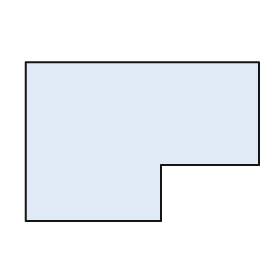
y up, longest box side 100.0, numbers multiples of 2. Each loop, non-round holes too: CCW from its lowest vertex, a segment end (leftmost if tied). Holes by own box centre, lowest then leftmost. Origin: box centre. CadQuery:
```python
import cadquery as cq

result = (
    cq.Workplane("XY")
    .moveTo(-50.0, -34.0)
    .lineTo(8.0, -34.0)
    .lineTo(8.0, -10.0)
    .lineTo(50.0, -10.0)
    .lineTo(50.0, 34.0)
    .lineTo(-50.0, 34.0)
    .close()
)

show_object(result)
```